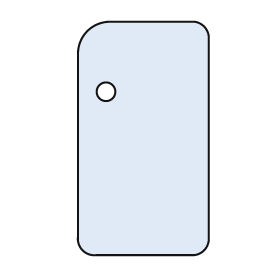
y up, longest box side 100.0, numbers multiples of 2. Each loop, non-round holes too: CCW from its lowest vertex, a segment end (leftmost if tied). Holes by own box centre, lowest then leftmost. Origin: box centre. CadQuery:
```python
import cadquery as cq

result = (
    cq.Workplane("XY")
    .moveTo(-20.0, -50.0)
    .lineTo(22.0, -50.0)
    .threePointArc((26.0, -48.0), (28.0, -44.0))
    .lineTo(28.0, 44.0)
    .threePointArc((26.0, 48.0), (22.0, 50.0))
    .lineTo(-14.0, 50.0)
    .threePointArc((-24.0, 46.0), (-28.0, 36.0))
    .lineTo(-28.0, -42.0)
    .threePointArc((-26.0, -48.0), (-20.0, -50.0))
    .close()
    .moveTo(-16.0, 20.0)
    .circle(4.0)
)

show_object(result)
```